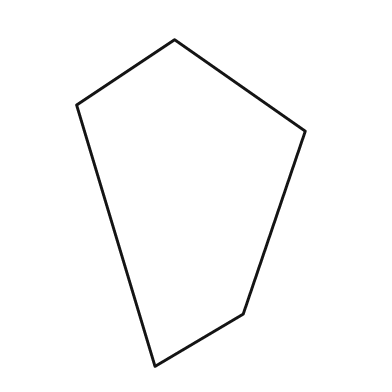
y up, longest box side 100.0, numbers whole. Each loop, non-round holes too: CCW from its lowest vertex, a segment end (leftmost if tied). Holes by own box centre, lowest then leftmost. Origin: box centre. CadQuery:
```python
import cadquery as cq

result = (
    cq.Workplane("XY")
    .moveTo(-11.0, -50.0)
    .lineTo(16.0, -34.0)
    .lineTo(35.0, 22.0)
    .lineTo(-5.0, 50.0)
    .lineTo(-35.0, 30.0)
    .close()
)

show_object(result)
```